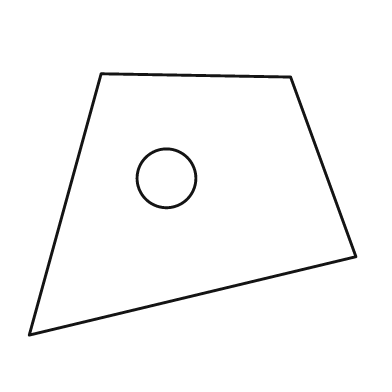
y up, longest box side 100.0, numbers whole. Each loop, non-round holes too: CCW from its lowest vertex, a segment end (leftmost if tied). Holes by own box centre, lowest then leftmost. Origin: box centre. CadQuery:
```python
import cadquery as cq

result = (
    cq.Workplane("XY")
    .moveTo(-50.0, -40.0)
    .lineTo(50.0, -16.0)
    .lineTo(30.0, 39.0)
    .lineTo(-28.0, 40.0)
    .close()
    .moveTo(-8.0, 8.0)
    .circle(9.0)
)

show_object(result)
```